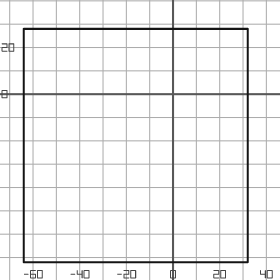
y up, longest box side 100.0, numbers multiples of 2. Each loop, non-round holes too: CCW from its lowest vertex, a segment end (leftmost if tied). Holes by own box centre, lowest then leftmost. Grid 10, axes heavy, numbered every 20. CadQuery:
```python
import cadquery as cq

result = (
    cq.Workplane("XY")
    .moveTo(-64.0, -72.0)
    .lineTo(32.0, -72.0)
    .lineTo(32.0, 28.0)
    .lineTo(-64.0, 28.0)
    .close()
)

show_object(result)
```